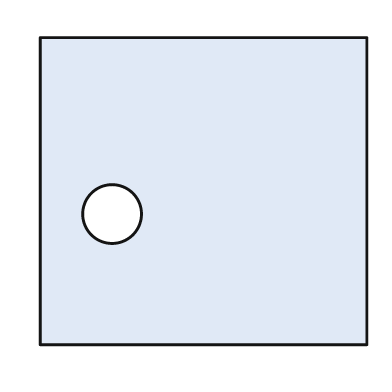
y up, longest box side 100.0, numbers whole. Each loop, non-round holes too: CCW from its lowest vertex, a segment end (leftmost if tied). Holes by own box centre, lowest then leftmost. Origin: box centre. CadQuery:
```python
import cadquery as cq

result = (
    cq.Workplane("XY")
    .moveTo(-50.0, -47.0)
    .lineTo(50.0, -47.0)
    .lineTo(50.0, 47.0)
    .lineTo(-50.0, 47.0)
    .close()
    .moveTo(-28.0, -7.0)
    .circle(9.0)
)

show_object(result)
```